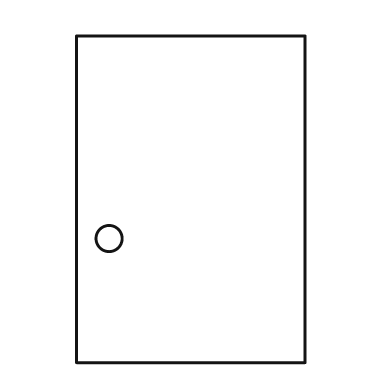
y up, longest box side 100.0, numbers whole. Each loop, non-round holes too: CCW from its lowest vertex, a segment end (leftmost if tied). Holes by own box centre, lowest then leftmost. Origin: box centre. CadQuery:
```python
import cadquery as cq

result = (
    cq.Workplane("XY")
    .moveTo(-35.0, -50.0)
    .lineTo(35.0, -50.0)
    .lineTo(35.0, 50.0)
    .lineTo(-35.0, 50.0)
    .close()
    .moveTo(-25.0, -12.0)
    .circle(4.0)
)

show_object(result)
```